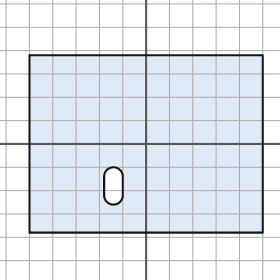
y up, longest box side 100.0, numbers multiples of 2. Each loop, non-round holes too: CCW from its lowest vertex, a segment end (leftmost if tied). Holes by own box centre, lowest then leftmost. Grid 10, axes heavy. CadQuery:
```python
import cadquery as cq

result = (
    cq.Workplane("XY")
    .moveTo(-50.0, -38.0)
    .lineTo(50.0, -38.0)
    .lineTo(50.0, 38.0)
    .lineTo(-50.0, 38.0)
    .close()
    .moveTo(-18.0, -22.0)
    .threePointArc((-14.0, -26.0), (-10.0, -22.0))
    .lineTo(-10.0, -14.0)
    .threePointArc((-14.0, -10.0), (-18.0, -14.0))
    .close()
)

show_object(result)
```